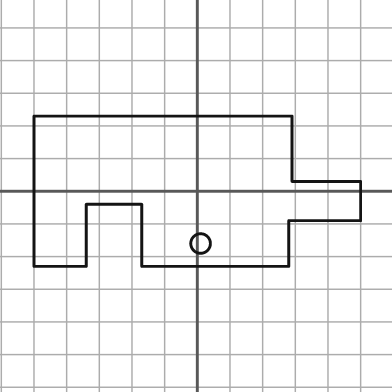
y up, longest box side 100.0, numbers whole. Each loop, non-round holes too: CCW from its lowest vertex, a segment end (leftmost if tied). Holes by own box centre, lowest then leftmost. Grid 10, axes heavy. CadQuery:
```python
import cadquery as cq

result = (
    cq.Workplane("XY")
    .moveTo(-50.0, -23.0)
    .lineTo(-34.0, -23.0)
    .lineTo(-34.0, -4.0)
    .lineTo(-17.0, -4.0)
    .lineTo(-17.0, -23.0)
    .lineTo(28.0, -23.0)
    .lineTo(28.0, -9.0)
    .lineTo(50.0, -9.0)
    .lineTo(50.0, 3.0)
    .lineTo(29.0, 3.0)
    .lineTo(29.0, 23.0)
    .lineTo(-50.0, 23.0)
    .close()
    .moveTo(1.0, -16.0)
    .circle(3.0)
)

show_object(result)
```